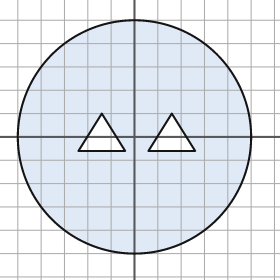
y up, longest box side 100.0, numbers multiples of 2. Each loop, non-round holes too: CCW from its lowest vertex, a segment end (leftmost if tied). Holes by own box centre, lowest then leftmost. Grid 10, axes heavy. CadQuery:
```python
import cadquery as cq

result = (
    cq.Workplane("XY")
    .moveTo(0.0, 0.0)
    .circle(50.0)
    .moveTo(-24.0, -6.0)
    .lineTo(-4.0, -6.0)
    .lineTo(-14.0, 10.0)
    .close()
    .moveTo(6.0, -6.0)
    .lineTo(26.0, -6.0)
    .lineTo(16.0, 10.0)
    .close()
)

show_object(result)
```